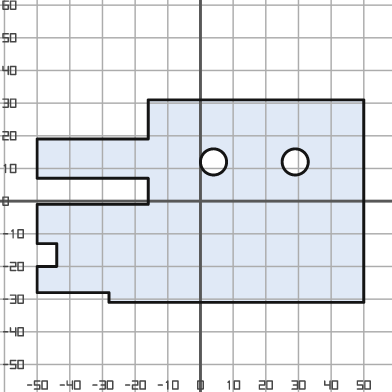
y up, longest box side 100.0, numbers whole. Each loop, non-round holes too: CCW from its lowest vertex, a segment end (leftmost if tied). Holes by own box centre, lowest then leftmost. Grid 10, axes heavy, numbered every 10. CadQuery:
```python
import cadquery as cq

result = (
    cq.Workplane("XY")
    .moveTo(-28.0, -31.0)
    .lineTo(50.0, -31.0)
    .lineTo(50.0, 31.0)
    .lineTo(-16.0, 31.0)
    .lineTo(-16.0, 19.0)
    .lineTo(-50.0, 19.0)
    .lineTo(-50.0, 7.0)
    .lineTo(-16.0, 7.0)
    .lineTo(-16.0, -1.0)
    .lineTo(-50.0, -1.0)
    .lineTo(-50.0, -13.0)
    .lineTo(-44.0, -13.0)
    .lineTo(-44.0, -20.0)
    .lineTo(-50.0, -20.0)
    .lineTo(-50.0, -28.0)
    .lineTo(-28.0, -28.0)
    .close()
    .moveTo(4.0, 12.0)
    .circle(4.0)
    .moveTo(29.0, 12.0)
    .circle(4.0)
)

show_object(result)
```